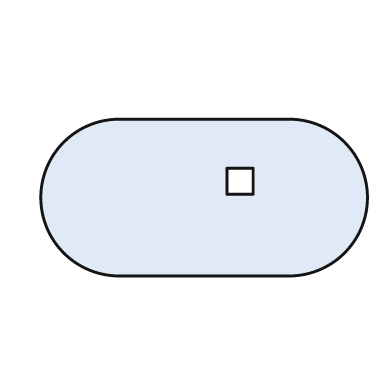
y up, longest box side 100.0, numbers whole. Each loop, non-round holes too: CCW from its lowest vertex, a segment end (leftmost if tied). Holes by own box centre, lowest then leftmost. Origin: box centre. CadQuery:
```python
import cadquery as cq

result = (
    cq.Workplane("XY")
    .moveTo(-26.0, -24.0)
    .lineTo(26.0, -24.0)
    .threePointArc((50.0, 0.0), (26.0, 24.0))
    .lineTo(-26.0, 24.0)
    .threePointArc((-50.0, 0.0), (-26.0, -24.0))
    .close()
    .moveTo(7.0, 1.0)
    .lineTo(15.0, 1.0)
    .lineTo(15.0, 9.0)
    .lineTo(7.0, 9.0)
    .close()
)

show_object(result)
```